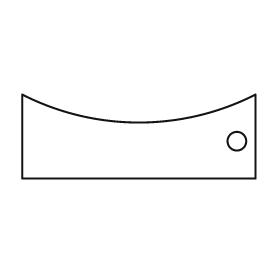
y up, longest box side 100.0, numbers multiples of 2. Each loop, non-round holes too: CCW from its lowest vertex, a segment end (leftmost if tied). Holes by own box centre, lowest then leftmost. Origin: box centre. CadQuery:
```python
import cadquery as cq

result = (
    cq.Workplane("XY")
    .moveTo(-50.0, -18.0)
    .lineTo(50.0, -18.0)
    .lineTo(50.0, 18.0)
    .threePointArc((0.0, 6.0), (-50.0, 18.0))
    .close()
    .moveTo(42.0, -2.0)
    .circle(4.0)
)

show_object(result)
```